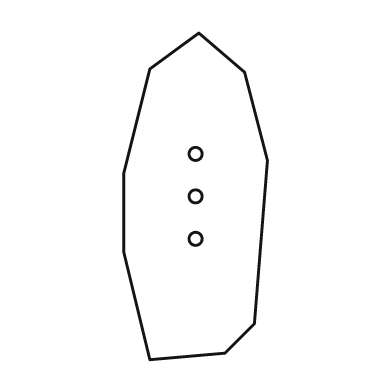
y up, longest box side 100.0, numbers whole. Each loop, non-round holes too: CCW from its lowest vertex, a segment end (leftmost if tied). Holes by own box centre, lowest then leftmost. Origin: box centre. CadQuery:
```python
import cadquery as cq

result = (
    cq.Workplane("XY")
    .moveTo(-14.0, -50.0)
    .lineTo(9.0, -48.0)
    .lineTo(18.0, -39.0)
    .lineTo(22.0, 11.0)
    .lineTo(15.0, 38.0)
    .lineTo(1.0, 50.0)
    .lineTo(-14.0, 39.0)
    .lineTo(-22.0, 7.0)
    .lineTo(-22.0, -17.0)
    .close()
    .moveTo(0.0, -13.0)
    .circle(2.0)
    .moveTo(0.0, 0.0)
    .circle(2.0)
    .moveTo(0.0, 13.0)
    .circle(2.0)
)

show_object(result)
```